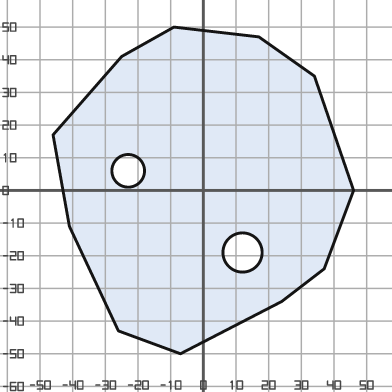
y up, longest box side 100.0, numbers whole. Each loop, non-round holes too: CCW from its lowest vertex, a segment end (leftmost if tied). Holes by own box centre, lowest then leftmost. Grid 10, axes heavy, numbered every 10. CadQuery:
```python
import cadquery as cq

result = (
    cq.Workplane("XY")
    .moveTo(-7.0, -50.0)
    .lineTo(24.0, -34.0)
    .lineTo(37.0, -24.0)
    .lineTo(46.0, 0.0)
    .lineTo(34.0, 35.0)
    .lineTo(17.0, 47.0)
    .lineTo(-9.0, 50.0)
    .lineTo(-25.0, 41.0)
    .lineTo(-46.0, 17.0)
    .lineTo(-41.0, -11.0)
    .lineTo(-26.0, -43.0)
    .close()
    .moveTo(12.0, -19.0)
    .circle(6.0)
    .moveTo(-23.0, 6.0)
    .circle(5.0)
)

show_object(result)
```